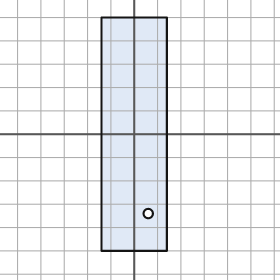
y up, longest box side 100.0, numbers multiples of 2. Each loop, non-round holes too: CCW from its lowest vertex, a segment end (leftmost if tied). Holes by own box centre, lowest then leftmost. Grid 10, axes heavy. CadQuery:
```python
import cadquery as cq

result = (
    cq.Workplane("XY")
    .moveTo(-14.0, -50.0)
    .lineTo(14.0, -50.0)
    .lineTo(14.0, 50.0)
    .lineTo(-14.0, 50.0)
    .close()
    .moveTo(6.0, -34.0)
    .circle(2.0)
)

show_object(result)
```